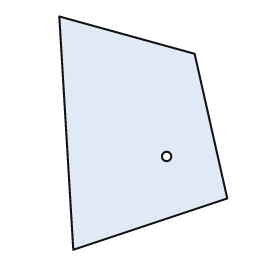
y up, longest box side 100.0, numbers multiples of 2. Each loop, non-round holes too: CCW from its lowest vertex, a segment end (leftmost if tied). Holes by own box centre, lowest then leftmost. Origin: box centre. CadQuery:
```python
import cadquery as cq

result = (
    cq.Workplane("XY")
    .moveTo(-30.0, -50.0)
    .lineTo(36.0, -28.0)
    .lineTo(22.0, 34.0)
    .lineTo(-36.0, 50.0)
    .close()
    .moveTo(10.0, -10.0)
    .circle(2.0)
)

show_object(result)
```